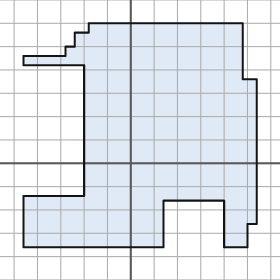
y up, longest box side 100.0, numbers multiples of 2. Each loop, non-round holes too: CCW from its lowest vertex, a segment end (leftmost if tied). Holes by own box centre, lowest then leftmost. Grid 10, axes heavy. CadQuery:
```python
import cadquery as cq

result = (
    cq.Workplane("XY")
    .moveTo(-46.0, -36.0)
    .lineTo(14.0, -36.0)
    .lineTo(14.0, -16.0)
    .lineTo(40.0, -16.0)
    .lineTo(40.0, -36.0)
    .lineTo(50.0, -36.0)
    .lineTo(50.0, -26.0)
    .lineTo(54.0, -26.0)
    .lineTo(54.0, 36.0)
    .lineTo(48.0, 36.0)
    .lineTo(48.0, 60.0)
    .lineTo(-18.0, 60.0)
    .lineTo(-18.0, 56.0)
    .lineTo(-24.0, 56.0)
    .lineTo(-24.0, 50.0)
    .lineTo(-28.0, 50.0)
    .lineTo(-28.0, 46.0)
    .lineTo(-46.0, 46.0)
    .lineTo(-46.0, 42.0)
    .lineTo(-20.0, 42.0)
    .lineTo(-20.0, -14.0)
    .lineTo(-46.0, -14.0)
    .close()
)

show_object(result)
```